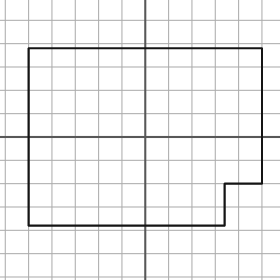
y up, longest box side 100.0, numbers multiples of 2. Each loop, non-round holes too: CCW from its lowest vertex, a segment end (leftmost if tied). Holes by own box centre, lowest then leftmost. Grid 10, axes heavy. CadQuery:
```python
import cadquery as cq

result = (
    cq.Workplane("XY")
    .moveTo(-50.0, -38.0)
    .lineTo(34.0, -38.0)
    .lineTo(34.0, -20.0)
    .lineTo(50.0, -20.0)
    .lineTo(50.0, 38.0)
    .lineTo(-50.0, 38.0)
    .close()
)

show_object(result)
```